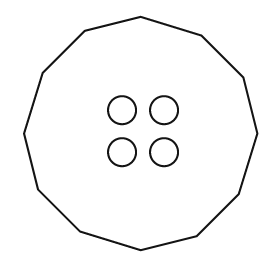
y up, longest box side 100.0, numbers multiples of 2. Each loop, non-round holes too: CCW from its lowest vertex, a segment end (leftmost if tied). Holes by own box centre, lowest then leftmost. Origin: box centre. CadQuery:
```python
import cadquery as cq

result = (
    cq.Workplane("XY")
    .moveTo(0.0, -50.0)
    .lineTo(24.0, -44.0)
    .lineTo(42.0, -26.0)
    .lineTo(50.0, 0.0)
    .lineTo(44.0, 24.0)
    .lineTo(26.0, 42.0)
    .lineTo(0.0, 50.0)
    .lineTo(-24.0, 44.0)
    .lineTo(-42.0, 26.0)
    .lineTo(-50.0, 0.0)
    .lineTo(-44.0, -24.0)
    .lineTo(-26.0, -42.0)
    .close()
    .moveTo(-8.0, -8.0)
    .circle(6.0)
    .moveTo(10.0, -8.0)
    .circle(6.0)
    .moveTo(-8.0, 10.0)
    .circle(6.0)
    .moveTo(10.0, 10.0)
    .circle(6.0)
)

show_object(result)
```